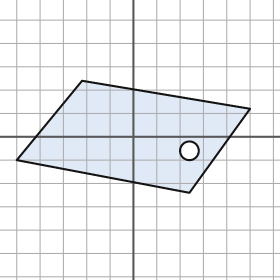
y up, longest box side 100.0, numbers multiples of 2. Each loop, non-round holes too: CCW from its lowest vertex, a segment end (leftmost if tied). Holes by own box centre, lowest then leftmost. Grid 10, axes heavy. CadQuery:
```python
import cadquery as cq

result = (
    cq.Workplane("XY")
    .moveTo(24.0, -24.0)
    .lineTo(50.0, 12.0)
    .lineTo(-22.0, 24.0)
    .lineTo(-50.0, -10.0)
    .close()
    .moveTo(24.0, -6.0)
    .circle(4.0)
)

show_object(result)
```